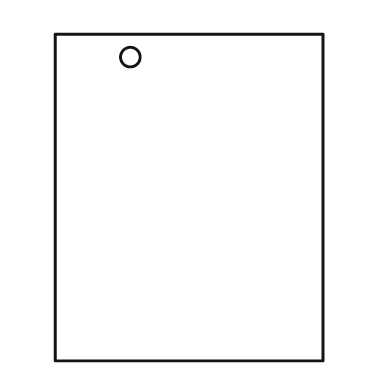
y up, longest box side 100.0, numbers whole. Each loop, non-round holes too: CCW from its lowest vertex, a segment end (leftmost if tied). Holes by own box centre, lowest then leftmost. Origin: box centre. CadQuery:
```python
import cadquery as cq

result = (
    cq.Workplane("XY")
    .moveTo(-41.0, -50.0)
    .lineTo(41.0, -50.0)
    .lineTo(41.0, 50.0)
    .lineTo(-41.0, 50.0)
    .close()
    .moveTo(-18.0, 43.0)
    .circle(3.0)
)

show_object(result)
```